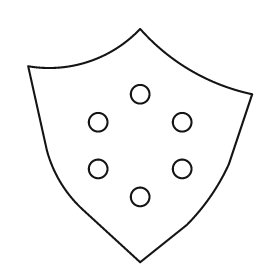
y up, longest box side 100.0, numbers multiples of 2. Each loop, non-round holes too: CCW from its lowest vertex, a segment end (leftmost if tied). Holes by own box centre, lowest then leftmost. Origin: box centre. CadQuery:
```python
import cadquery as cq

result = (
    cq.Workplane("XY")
    .moveTo(0.0, -50.0)
    .lineTo(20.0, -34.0)
    .threePointArc((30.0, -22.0), (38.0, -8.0))
    .lineTo(48.0, 22.0)
    .threePointArc((22.0, 32.0), (0.0, 50.0))
    .threePointArc((-22.0, 36.0), (-48.0, 34.0))
    .lineTo(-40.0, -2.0)
    .threePointArc((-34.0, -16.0), (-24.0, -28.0))
    .close()
    .moveTo(0.0, -22.0)
    .circle(4.0)
    .moveTo(-18.0, -10.0)
    .circle(4.0)
    .moveTo(18.0, -10.0)
    .circle(4.0)
    .moveTo(-18.0, 10.0)
    .circle(4.0)
    .moveTo(18.0, 10.0)
    .circle(4.0)
    .moveTo(0.0, 22.0)
    .circle(4.0)
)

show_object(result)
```